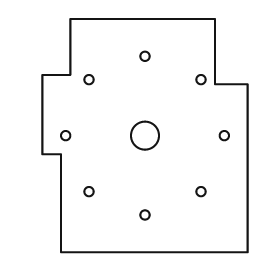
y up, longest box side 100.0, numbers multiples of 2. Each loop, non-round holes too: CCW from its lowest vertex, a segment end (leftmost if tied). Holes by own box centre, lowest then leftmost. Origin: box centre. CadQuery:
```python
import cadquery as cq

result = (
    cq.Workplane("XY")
    .moveTo(-36.0, -50.0)
    .lineTo(44.0, -50.0)
    .lineTo(44.0, 22.0)
    .lineTo(30.0, 22.0)
    .lineTo(30.0, 50.0)
    .lineTo(-32.0, 50.0)
    .lineTo(-32.0, 26.0)
    .lineTo(-44.0, 26.0)
    .lineTo(-44.0, -8.0)
    .lineTo(-36.0, -8.0)
    .close()
    .moveTo(0.0, -34.0)
    .circle(2.0)
    .moveTo(-24.0, -24.0)
    .circle(2.0)
    .moveTo(24.0, -24.0)
    .circle(2.0)
    .moveTo(-34.0, 0.0)
    .circle(2.0)
    .moveTo(0.0, 0.0)
    .circle(6.0)
    .moveTo(34.0, 0.0)
    .circle(2.0)
    .moveTo(-24.0, 24.0)
    .circle(2.0)
    .moveTo(24.0, 24.0)
    .circle(2.0)
    .moveTo(0.0, 34.0)
    .circle(2.0)
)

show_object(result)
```